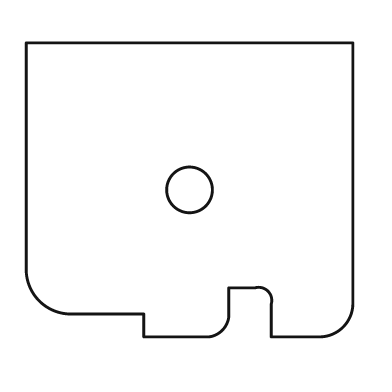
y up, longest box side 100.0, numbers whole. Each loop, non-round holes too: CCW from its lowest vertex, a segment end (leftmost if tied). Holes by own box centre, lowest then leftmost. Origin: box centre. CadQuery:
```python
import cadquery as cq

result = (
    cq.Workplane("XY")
    .moveTo(-14.0, -45.0)
    .lineTo(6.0, -45.0)
    .threePointArc((10.0, -43.0), (12.0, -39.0))
    .lineTo(12.0, -30.0)
    .lineTo(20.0, -30.0)
    .threePointArc((24.0, -31.0), (25.0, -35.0))
    .lineTo(25.0, -45.0)
    .lineTo(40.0, -45.0)
    .threePointArc((47.0, -42.0), (50.0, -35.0))
    .lineTo(50.0, 45.0)
    .lineTo(-50.0, 45.0)
    .lineTo(-50.0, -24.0)
    .threePointArc((-46.0, -34.0), (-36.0, -38.0))
    .lineTo(-14.0, -38.0)
    .close()
    .moveTo(0.0, 0.0)
    .circle(7.0)
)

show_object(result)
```